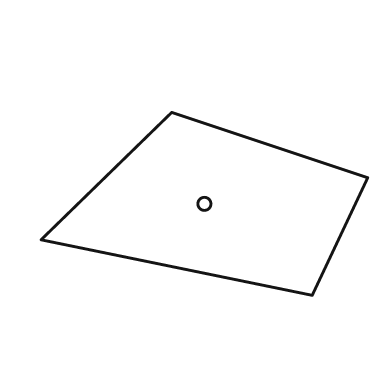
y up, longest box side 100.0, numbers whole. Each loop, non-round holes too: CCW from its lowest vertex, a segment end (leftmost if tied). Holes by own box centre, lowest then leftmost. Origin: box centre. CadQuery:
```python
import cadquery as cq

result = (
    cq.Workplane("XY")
    .moveTo(33.0, -28.0)
    .lineTo(50.0, 8.0)
    .lineTo(-10.0, 28.0)
    .lineTo(-50.0, -11.0)
    .close()
    .moveTo(0.0, 0.0)
    .circle(2.0)
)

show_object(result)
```